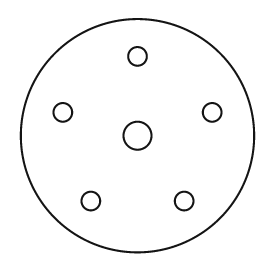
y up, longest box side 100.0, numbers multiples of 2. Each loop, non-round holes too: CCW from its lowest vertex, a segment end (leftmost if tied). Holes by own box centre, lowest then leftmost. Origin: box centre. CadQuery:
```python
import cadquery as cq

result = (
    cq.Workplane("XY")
    .moveTo(0.0, 0.0)
    .circle(50.0)
    .moveTo(-20.0, -28.0)
    .circle(4.0)
    .moveTo(20.0, -28.0)
    .circle(4.0)
    .moveTo(0.0, 0.0)
    .circle(6.0)
    .moveTo(-32.0, 10.0)
    .circle(4.0)
    .moveTo(32.0, 10.0)
    .circle(4.0)
    .moveTo(0.0, 34.0)
    .circle(4.0)
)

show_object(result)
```